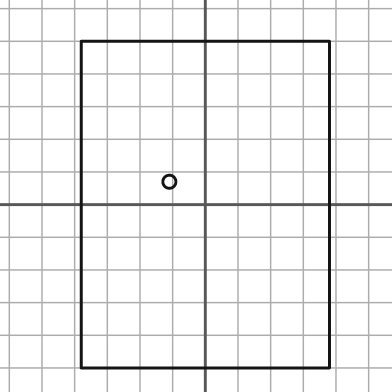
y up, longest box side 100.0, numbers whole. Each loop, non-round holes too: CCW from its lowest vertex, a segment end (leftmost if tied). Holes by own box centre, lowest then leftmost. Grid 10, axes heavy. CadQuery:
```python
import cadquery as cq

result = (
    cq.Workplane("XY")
    .moveTo(-38.0, -50.0)
    .lineTo(38.0, -50.0)
    .lineTo(38.0, 50.0)
    .lineTo(-38.0, 50.0)
    .close()
    .moveTo(-11.0, 7.0)
    .circle(2.0)
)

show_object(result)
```